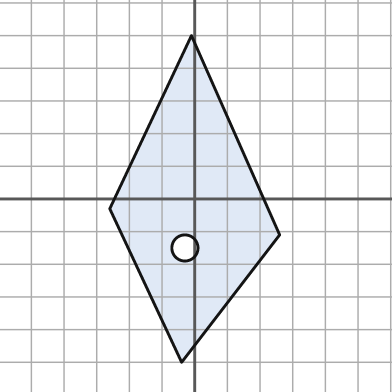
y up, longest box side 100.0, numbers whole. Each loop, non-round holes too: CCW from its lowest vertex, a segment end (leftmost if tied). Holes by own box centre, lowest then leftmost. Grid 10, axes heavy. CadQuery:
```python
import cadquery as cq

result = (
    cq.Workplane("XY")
    .moveTo(-4.0, -50.0)
    .lineTo(26.0, -11.0)
    .lineTo(-1.0, 50.0)
    .lineTo(-26.0, -3.0)
    .close()
    .moveTo(-3.0, -15.0)
    .circle(4.0)
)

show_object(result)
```